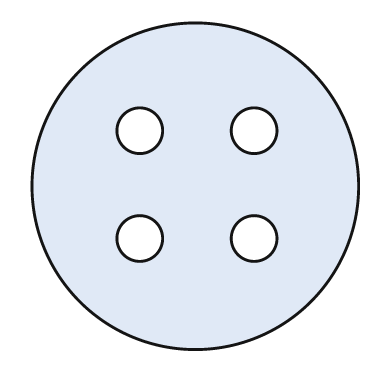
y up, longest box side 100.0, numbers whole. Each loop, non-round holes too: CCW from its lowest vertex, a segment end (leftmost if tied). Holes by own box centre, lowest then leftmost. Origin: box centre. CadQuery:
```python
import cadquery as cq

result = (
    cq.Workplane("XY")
    .moveTo(0.0, 0.0)
    .circle(50.0)
    .moveTo(-17.0, -16.0)
    .circle(7.0)
    .moveTo(18.0, -16.0)
    .circle(7.0)
    .moveTo(-17.0, 17.0)
    .circle(7.0)
    .moveTo(18.0, 17.0)
    .circle(7.0)
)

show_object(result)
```